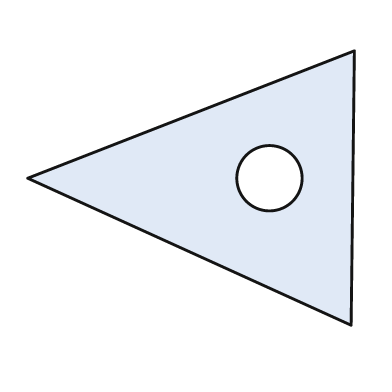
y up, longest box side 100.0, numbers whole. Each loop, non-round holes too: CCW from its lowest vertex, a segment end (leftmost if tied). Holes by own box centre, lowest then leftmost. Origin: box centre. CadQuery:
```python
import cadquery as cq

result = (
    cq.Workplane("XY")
    .moveTo(49.0, -42.0)
    .lineTo(50.0, 42.0)
    .lineTo(-50.0, 3.0)
    .close()
    .moveTo(24.0, 3.0)
    .circle(10.0)
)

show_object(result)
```